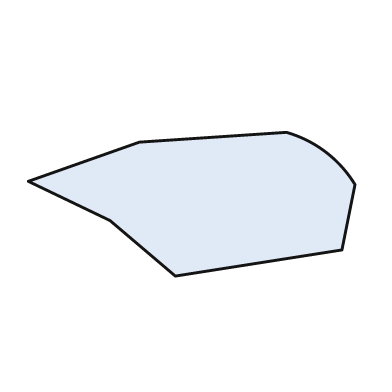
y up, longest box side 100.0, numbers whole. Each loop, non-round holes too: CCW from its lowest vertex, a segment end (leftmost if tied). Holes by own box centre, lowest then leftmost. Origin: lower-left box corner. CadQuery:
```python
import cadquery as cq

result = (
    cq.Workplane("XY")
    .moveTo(45.0, 0.0)
    .lineTo(96.0, 8.0)
    .lineTo(100.0, 28.0)
    .threePointArc((91.0, 38.0), (79.0, 44.0))
    .lineTo(34.0, 41.0)
    .lineTo(0.0, 29.0)
    .lineTo(25.0, 17.0)
    .close()
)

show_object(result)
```